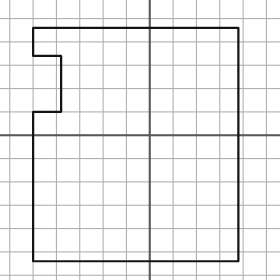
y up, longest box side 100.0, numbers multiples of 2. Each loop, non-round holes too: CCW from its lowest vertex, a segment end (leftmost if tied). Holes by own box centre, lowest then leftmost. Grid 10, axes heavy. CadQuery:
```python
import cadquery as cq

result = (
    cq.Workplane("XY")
    .moveTo(-50.0, -54.0)
    .lineTo(38.0, -54.0)
    .lineTo(38.0, 46.0)
    .lineTo(-50.0, 46.0)
    .lineTo(-50.0, 34.0)
    .lineTo(-38.0, 34.0)
    .lineTo(-38.0, 10.0)
    .lineTo(-50.0, 10.0)
    .close()
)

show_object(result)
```